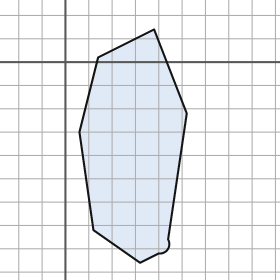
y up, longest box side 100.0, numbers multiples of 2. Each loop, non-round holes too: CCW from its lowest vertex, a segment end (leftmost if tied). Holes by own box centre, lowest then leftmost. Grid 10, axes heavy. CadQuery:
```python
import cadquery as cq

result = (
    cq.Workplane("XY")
    .moveTo(32.0, -86.0)
    .lineTo(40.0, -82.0)
    .threePointArc((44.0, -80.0), (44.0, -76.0))
    .lineTo(52.0, -22.0)
    .lineTo(38.0, 14.0)
    .lineTo(14.0, 2.0)
    .lineTo(6.0, -30.0)
    .lineTo(12.0, -72.0)
    .close()
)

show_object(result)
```